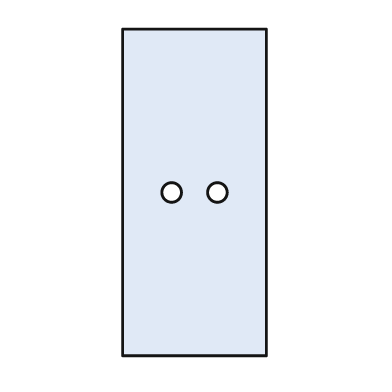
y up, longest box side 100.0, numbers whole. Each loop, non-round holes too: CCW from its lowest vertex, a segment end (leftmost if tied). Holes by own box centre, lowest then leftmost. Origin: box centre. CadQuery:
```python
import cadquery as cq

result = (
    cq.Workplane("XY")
    .moveTo(-22.0, -50.0)
    .lineTo(22.0, -50.0)
    .lineTo(22.0, 50.0)
    .lineTo(-22.0, 50.0)
    .close()
    .moveTo(-7.0, 0.0)
    .circle(3.0)
    .moveTo(7.0, 0.0)
    .circle(3.0)
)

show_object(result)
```